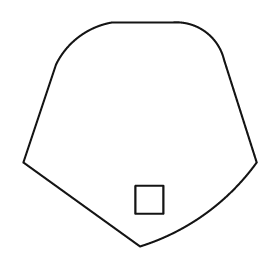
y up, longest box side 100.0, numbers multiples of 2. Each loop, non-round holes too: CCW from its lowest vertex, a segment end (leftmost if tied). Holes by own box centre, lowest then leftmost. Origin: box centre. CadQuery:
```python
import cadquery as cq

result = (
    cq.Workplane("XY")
    .moveTo(0.0, -48.0)
    .threePointArc((28.0, -34.0), (50.0, -12.0))
    .lineTo(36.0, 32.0)
    .threePointArc((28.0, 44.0), (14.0, 48.0))
    .lineTo(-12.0, 48.0)
    .threePointArc((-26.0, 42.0), (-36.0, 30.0))
    .lineTo(-50.0, -12.0)
    .close()
    .moveTo(-2.0, -34.0)
    .lineTo(10.0, -34.0)
    .lineTo(10.0, -22.0)
    .lineTo(-2.0, -22.0)
    .close()
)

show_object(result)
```